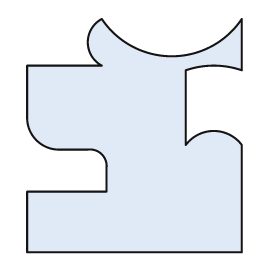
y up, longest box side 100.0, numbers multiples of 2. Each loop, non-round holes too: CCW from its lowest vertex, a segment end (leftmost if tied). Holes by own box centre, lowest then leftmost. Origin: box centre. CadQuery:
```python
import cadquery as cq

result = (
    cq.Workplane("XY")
    .moveTo(-46.0, -50.0)
    .lineTo(46.0, -50.0)
    .lineTo(46.0, -4.0)
    .threePointArc((34.0, 2.0), (22.0, -4.0))
    .lineTo(22.0, 28.0)
    .threePointArc((34.0, 30.0), (46.0, 28.0))
    .lineTo(46.0, 50.0)
    .threePointArc((16.0, 34.0), (-14.0, 50.0))
    .threePointArc((-20.0, 40.0), (-14.0, 30.0))
    .lineTo(-46.0, 30.0)
    .lineTo(-46.0, 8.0)
    .threePointArc((-42.0, -2.0), (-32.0, -6.0))
    .lineTo(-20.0, -6.0)
    .threePointArc((-14.0, -8.0), (-12.0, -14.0))
    .lineTo(-12.0, -24.0)
    .lineTo(-46.0, -24.0)
    .close()
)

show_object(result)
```